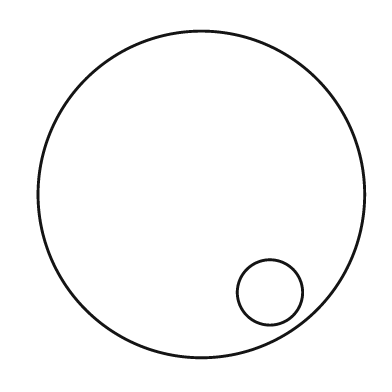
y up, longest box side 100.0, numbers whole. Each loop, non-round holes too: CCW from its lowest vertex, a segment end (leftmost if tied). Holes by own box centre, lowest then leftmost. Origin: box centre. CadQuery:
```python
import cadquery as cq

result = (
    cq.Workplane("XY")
    .moveTo(0.0, 0.0)
    .circle(50.0)
    .moveTo(21.0, -30.0)
    .circle(10.0)
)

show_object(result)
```